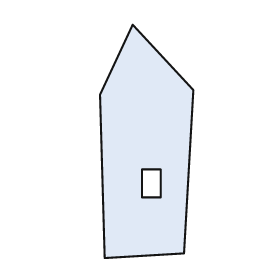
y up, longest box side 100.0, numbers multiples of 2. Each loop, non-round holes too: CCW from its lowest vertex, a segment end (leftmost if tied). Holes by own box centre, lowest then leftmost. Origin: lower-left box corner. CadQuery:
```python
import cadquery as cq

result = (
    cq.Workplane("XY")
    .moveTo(2.0, 0.0)
    .lineTo(36.0, 2.0)
    .lineTo(40.0, 72.0)
    .lineTo(14.0, 100.0)
    .lineTo(0.0, 70.0)
    .close()
    .moveTo(18.0, 26.0)
    .lineTo(26.0, 26.0)
    .lineTo(26.0, 38.0)
    .lineTo(18.0, 38.0)
    .close()
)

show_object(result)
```